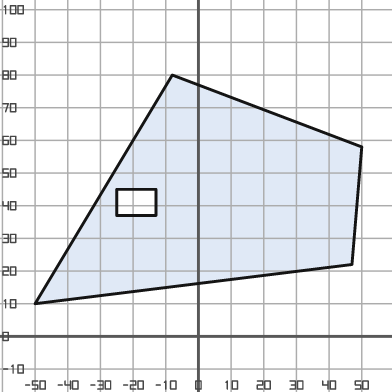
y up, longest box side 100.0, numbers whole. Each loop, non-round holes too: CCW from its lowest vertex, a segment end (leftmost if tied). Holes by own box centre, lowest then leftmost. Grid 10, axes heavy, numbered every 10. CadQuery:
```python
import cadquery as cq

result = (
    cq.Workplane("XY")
    .moveTo(-50.0, 10.0)
    .lineTo(47.0, 22.0)
    .lineTo(50.0, 58.0)
    .lineTo(-8.0, 80.0)
    .close()
    .moveTo(-25.0, 37.0)
    .lineTo(-13.0, 37.0)
    .lineTo(-13.0, 45.0)
    .lineTo(-25.0, 45.0)
    .close()
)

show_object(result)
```